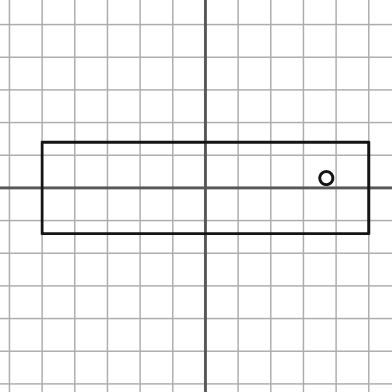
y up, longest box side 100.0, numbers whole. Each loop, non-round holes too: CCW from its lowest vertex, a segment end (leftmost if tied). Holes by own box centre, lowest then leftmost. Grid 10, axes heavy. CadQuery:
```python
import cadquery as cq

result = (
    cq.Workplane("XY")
    .moveTo(-50.0, -14.0)
    .lineTo(50.0, -14.0)
    .lineTo(50.0, 14.0)
    .lineTo(-50.0, 14.0)
    .close()
    .moveTo(37.0, 3.0)
    .circle(2.0)
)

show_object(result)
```